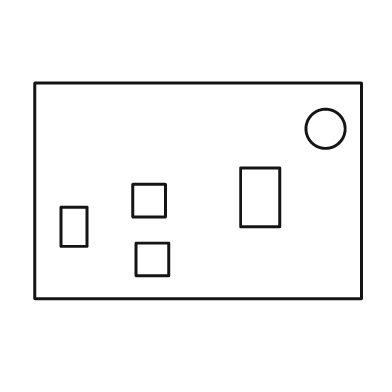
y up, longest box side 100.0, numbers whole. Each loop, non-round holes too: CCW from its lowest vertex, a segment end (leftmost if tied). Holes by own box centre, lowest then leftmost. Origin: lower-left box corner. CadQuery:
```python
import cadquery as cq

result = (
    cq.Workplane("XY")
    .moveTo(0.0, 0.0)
    .lineTo(100.0, 0.0)
    .lineTo(100.0, 66.0)
    .lineTo(0.0, 66.0)
    .close()
    .moveTo(31.0, 7.0)
    .lineTo(41.0, 7.0)
    .lineTo(41.0, 17.0)
    .lineTo(31.0, 17.0)
    .close()
    .moveTo(8.0, 16.0)
    .lineTo(16.0, 16.0)
    .lineTo(16.0, 28.0)
    .lineTo(8.0, 28.0)
    .close()
    .moveTo(30.0, 25.0)
    .lineTo(40.0, 25.0)
    .lineTo(40.0, 35.0)
    .lineTo(30.0, 35.0)
    .close()
    .moveTo(63.0, 22.0)
    .lineTo(75.0, 22.0)
    .lineTo(75.0, 40.0)
    .lineTo(63.0, 40.0)
    .close()
    .moveTo(89.0, 52.0)
    .circle(6.0)
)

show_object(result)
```